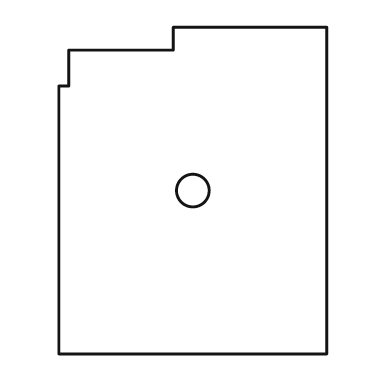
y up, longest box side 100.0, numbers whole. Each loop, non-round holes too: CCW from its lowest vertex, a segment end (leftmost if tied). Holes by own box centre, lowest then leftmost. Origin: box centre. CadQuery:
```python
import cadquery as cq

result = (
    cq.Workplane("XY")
    .moveTo(-41.0, -50.0)
    .lineTo(41.0, -50.0)
    .lineTo(41.0, 50.0)
    .lineTo(-6.0, 50.0)
    .lineTo(-6.0, 43.0)
    .lineTo(-38.0, 43.0)
    .lineTo(-38.0, 32.0)
    .lineTo(-41.0, 32.0)
    .close()
    .moveTo(0.0, 0.0)
    .circle(5.0)
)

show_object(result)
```